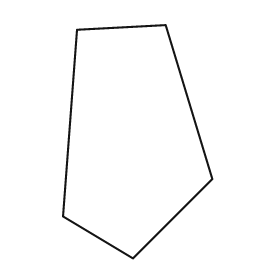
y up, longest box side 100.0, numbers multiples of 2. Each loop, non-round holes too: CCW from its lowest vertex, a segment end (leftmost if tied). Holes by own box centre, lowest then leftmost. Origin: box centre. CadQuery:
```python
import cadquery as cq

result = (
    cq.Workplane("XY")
    .moveTo(-2.0, -50.0)
    .lineTo(32.0, -16.0)
    .lineTo(12.0, 50.0)
    .lineTo(-26.0, 48.0)
    .lineTo(-32.0, -32.0)
    .close()
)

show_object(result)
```